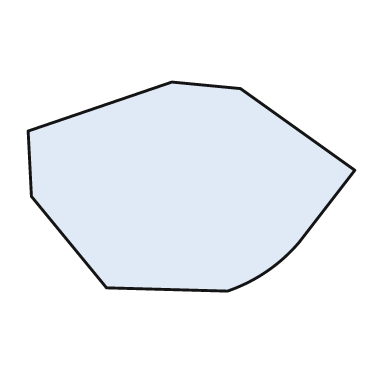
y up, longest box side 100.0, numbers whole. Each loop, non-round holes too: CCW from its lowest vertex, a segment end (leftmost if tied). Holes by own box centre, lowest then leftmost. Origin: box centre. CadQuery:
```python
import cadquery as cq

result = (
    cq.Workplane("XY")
    .moveTo(11.0, -32.0)
    .threePointArc((23.0, -26.0), (33.0, -17.0))
    .lineTo(50.0, 5.0)
    .lineTo(15.0, 30.0)
    .lineTo(-6.0, 32.0)
    .lineTo(-50.0, 17.0)
    .lineTo(-49.0, -3.0)
    .lineTo(-26.0, -31.0)
    .close()
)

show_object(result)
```